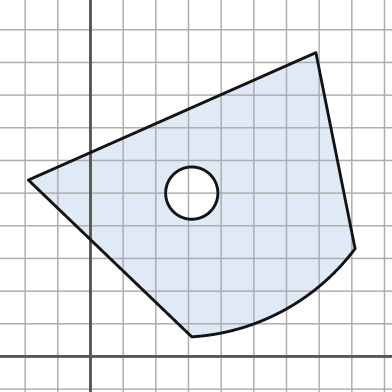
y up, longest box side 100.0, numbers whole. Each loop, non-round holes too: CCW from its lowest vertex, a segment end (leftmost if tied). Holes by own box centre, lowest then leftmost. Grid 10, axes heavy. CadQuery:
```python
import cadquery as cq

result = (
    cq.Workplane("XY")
    .moveTo(31.0, 6.0)
    .threePointArc((59.0, 14.0), (81.0, 33.0))
    .lineTo(69.0, 93.0)
    .lineTo(-19.0, 54.0)
    .close()
    .moveTo(31.0, 50.0)
    .circle(8.0)
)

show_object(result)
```